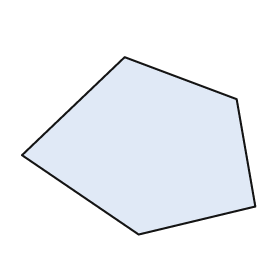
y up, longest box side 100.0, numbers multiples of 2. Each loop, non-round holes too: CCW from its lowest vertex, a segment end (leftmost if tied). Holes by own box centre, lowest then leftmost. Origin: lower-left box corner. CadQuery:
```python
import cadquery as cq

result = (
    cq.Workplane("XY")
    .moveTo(50.0, 0.0)
    .lineTo(100.0, 12.0)
    .lineTo(92.0, 58.0)
    .lineTo(44.0, 76.0)
    .lineTo(0.0, 34.0)
    .close()
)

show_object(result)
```